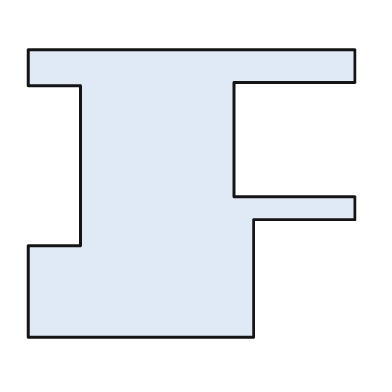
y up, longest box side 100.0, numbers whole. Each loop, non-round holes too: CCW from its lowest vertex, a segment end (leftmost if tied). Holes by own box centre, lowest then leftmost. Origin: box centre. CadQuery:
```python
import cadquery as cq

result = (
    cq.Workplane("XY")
    .moveTo(-50.0, -44.0)
    .lineTo(19.0, -44.0)
    .lineTo(19.0, -8.0)
    .lineTo(50.0, -8.0)
    .lineTo(50.0, -1.0)
    .lineTo(13.0, -1.0)
    .lineTo(13.0, 34.0)
    .lineTo(50.0, 34.0)
    .lineTo(50.0, 44.0)
    .lineTo(-50.0, 44.0)
    .lineTo(-50.0, 33.0)
    .lineTo(-34.0, 33.0)
    .lineTo(-34.0, -16.0)
    .lineTo(-50.0, -16.0)
    .close()
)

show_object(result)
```